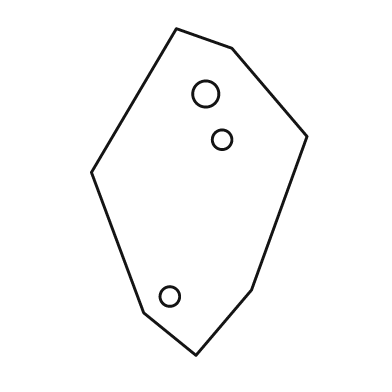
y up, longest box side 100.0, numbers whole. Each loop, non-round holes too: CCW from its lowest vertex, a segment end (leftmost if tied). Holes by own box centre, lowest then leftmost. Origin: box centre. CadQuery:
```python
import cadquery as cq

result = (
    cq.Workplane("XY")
    .moveTo(-1.0, -50.0)
    .lineTo(16.0, -30.0)
    .lineTo(33.0, 17.0)
    .lineTo(10.0, 44.0)
    .lineTo(-7.0, 50.0)
    .lineTo(-33.0, 6.0)
    .lineTo(-17.0, -37.0)
    .close()
    .moveTo(-9.0, -32.0)
    .circle(3.0)
    .moveTo(7.0, 16.0)
    .circle(3.0)
    .moveTo(2.0, 30.0)
    .circle(4.0)
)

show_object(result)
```